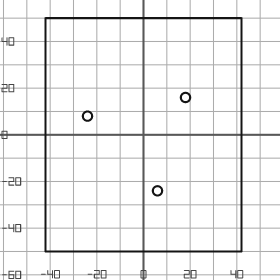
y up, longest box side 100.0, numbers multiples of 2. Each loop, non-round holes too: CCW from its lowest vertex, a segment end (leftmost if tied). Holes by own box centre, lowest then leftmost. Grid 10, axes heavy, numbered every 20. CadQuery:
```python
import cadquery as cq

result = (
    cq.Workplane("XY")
    .moveTo(-42.0, -50.0)
    .lineTo(42.0, -50.0)
    .lineTo(42.0, 50.0)
    .lineTo(-42.0, 50.0)
    .close()
    .moveTo(6.0, -24.0)
    .circle(2.0)
    .moveTo(-24.0, 8.0)
    .circle(2.0)
    .moveTo(18.0, 16.0)
    .circle(2.0)
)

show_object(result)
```